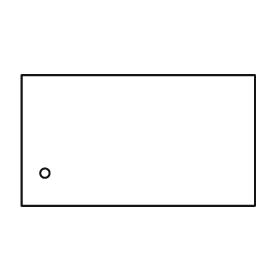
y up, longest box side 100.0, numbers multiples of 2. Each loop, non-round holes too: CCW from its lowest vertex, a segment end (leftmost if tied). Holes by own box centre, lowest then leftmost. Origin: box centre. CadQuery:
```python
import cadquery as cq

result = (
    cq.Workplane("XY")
    .moveTo(-50.0, -28.0)
    .lineTo(50.0, -28.0)
    .lineTo(50.0, 28.0)
    .lineTo(-50.0, 28.0)
    .close()
    .moveTo(-40.0, -14.0)
    .circle(2.0)
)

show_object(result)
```